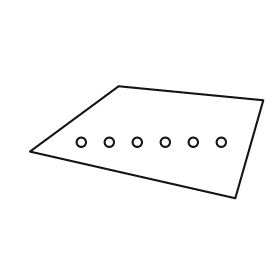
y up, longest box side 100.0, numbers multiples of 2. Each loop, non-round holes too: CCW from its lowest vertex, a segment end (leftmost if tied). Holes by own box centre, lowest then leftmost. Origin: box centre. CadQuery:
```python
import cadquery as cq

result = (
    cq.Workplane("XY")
    .moveTo(38.0, -24.0)
    .lineTo(50.0, 18.0)
    .lineTo(-12.0, 24.0)
    .lineTo(-50.0, -4.0)
    .close()
    .moveTo(-28.0, 0.0)
    .circle(2.0)
    .moveTo(-16.0, 0.0)
    .circle(2.0)
    .moveTo(-4.0, 0.0)
    .circle(2.0)
    .moveTo(8.0, 0.0)
    .circle(2.0)
    .moveTo(20.0, 0.0)
    .circle(2.0)
    .moveTo(32.0, 0.0)
    .circle(2.0)
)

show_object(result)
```